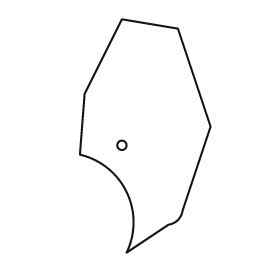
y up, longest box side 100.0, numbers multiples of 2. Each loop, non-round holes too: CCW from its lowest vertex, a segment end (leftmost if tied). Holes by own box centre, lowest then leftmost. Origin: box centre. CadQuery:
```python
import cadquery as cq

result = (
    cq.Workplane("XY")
    .moveTo(-8.0, -50.0)
    .lineTo(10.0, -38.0)
    .threePointArc((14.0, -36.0), (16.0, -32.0))
    .lineTo(28.0, 4.0)
    .lineTo(14.0, 46.0)
    .lineTo(-10.0, 50.0)
    .lineTo(-26.0, 18.0)
    .lineTo(-28.0, -8.0)
    .threePointArc((-8.0, -24.0), (-8.0, -50.0))
    .close()
    .moveTo(-10.0, -4.0)
    .circle(2.0)
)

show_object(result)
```